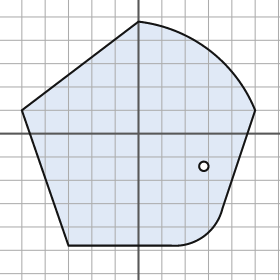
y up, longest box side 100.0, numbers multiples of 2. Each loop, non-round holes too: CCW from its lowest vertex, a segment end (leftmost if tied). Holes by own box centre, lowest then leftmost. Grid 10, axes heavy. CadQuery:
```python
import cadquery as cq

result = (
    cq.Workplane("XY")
    .moveTo(-30.0, -48.0)
    .lineTo(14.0, -48.0)
    .threePointArc((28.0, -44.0), (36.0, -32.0))
    .lineTo(50.0, 10.0)
    .threePointArc((30.0, 36.0), (0.0, 48.0))
    .lineTo(-50.0, 10.0)
    .close()
    .moveTo(28.0, -14.0)
    .circle(2.0)
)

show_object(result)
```